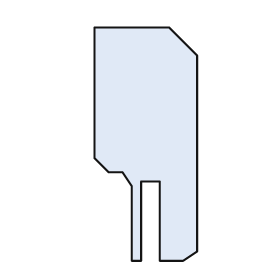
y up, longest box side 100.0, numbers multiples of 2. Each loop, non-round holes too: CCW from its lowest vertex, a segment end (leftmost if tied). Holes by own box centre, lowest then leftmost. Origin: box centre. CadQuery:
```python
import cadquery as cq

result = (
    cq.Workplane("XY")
    .moveTo(-6.0, -50.0)
    .lineTo(-2.0, -50.0)
    .lineTo(-2.0, -16.0)
    .lineTo(6.0, -16.0)
    .lineTo(6.0, -50.0)
    .lineTo(16.0, -50.0)
    .lineTo(22.0, -46.0)
    .lineTo(22.0, 38.0)
    .lineTo(10.0, 50.0)
    .lineTo(-22.0, 50.0)
    .lineTo(-22.0, -6.0)
    .lineTo(-16.0, -12.0)
    .lineTo(-10.0, -12.0)
    .lineTo(-6.0, -18.0)
    .close()
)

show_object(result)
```